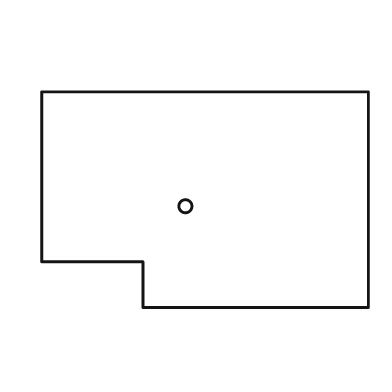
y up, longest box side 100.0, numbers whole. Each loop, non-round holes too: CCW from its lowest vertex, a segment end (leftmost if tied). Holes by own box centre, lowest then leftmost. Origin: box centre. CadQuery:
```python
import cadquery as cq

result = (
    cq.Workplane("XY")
    .moveTo(-19.0, -33.0)
    .lineTo(50.0, -33.0)
    .lineTo(50.0, 33.0)
    .lineTo(-50.0, 33.0)
    .lineTo(-50.0, -19.0)
    .lineTo(-19.0, -19.0)
    .close()
    .moveTo(-6.0, -2.0)
    .circle(2.0)
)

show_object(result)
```